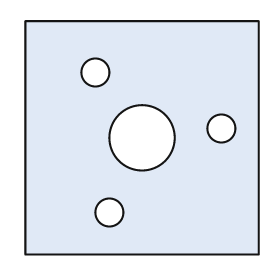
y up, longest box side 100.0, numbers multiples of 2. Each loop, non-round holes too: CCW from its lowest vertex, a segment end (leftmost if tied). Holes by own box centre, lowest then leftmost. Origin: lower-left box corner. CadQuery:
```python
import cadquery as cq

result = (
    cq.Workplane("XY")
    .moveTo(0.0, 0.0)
    .lineTo(100.0, 0.0)
    .lineTo(100.0, 100.0)
    .lineTo(0.0, 100.0)
    .close()
    .moveTo(36.0, 18.0)
    .circle(6.0)
    .moveTo(50.0, 50.0)
    .circle(14.0)
    .moveTo(84.0, 54.0)
    .circle(6.0)
    .moveTo(30.0, 78.0)
    .circle(6.0)
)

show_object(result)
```